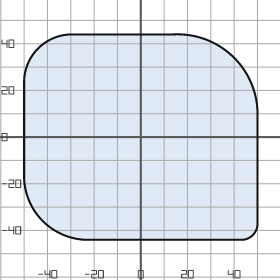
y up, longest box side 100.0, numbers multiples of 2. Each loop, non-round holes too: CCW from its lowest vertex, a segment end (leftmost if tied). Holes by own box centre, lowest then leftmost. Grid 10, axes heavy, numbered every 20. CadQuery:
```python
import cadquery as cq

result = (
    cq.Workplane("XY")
    .moveTo(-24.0, -44.0)
    .lineTo(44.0, -44.0)
    .threePointArc((48.0, -42.0), (50.0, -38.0))
    .lineTo(50.0, 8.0)
    .threePointArc((40.0, 34.0), (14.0, 44.0))
    .lineTo(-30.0, 44.0)
    .threePointArc((-44.0, 38.0), (-50.0, 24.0))
    .lineTo(-50.0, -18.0)
    .threePointArc((-42.0, -36.0), (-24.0, -44.0))
    .close()
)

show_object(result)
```